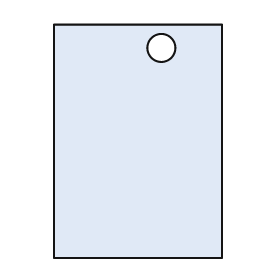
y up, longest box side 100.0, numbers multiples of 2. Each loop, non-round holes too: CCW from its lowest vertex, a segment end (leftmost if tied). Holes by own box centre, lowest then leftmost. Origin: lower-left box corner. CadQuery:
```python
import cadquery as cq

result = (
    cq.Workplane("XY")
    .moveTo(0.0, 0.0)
    .lineTo(72.0, 0.0)
    .lineTo(72.0, 100.0)
    .lineTo(0.0, 100.0)
    .close()
    .moveTo(46.0, 90.0)
    .circle(6.0)
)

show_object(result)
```